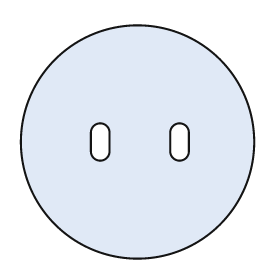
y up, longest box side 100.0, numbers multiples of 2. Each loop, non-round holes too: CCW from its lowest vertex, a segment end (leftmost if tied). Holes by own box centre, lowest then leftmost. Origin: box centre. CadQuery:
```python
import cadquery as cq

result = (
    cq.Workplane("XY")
    .moveTo(0.0, 0.0)
    .circle(50.0)
    .moveTo(-20.0, -4.0)
    .threePointArc((-16.0, -8.0), (-12.0, -4.0))
    .lineTo(-12.0, 4.0)
    .threePointArc((-16.0, 8.0), (-20.0, 4.0))
    .close()
    .moveTo(14.0, -4.0)
    .threePointArc((18.0, -8.0), (22.0, -4.0))
    .lineTo(22.0, 4.0)
    .threePointArc((18.0, 8.0), (14.0, 4.0))
    .close()
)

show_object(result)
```